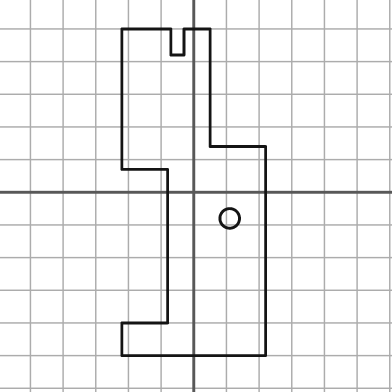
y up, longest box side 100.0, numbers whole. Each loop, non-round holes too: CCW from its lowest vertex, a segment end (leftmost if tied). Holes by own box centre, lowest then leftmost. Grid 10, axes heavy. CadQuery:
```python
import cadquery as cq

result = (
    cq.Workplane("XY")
    .moveTo(-22.0, -50.0)
    .lineTo(22.0, -50.0)
    .lineTo(22.0, 14.0)
    .lineTo(5.0, 14.0)
    .lineTo(5.0, 50.0)
    .lineTo(-3.0, 50.0)
    .lineTo(-3.0, 42.0)
    .lineTo(-7.0, 42.0)
    .lineTo(-7.0, 50.0)
    .lineTo(-22.0, 50.0)
    .lineTo(-22.0, 7.0)
    .lineTo(-8.0, 7.0)
    .lineTo(-8.0, -40.0)
    .lineTo(-22.0, -40.0)
    .close()
    .moveTo(11.0, -8.0)
    .circle(3.0)
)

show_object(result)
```